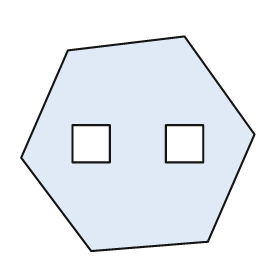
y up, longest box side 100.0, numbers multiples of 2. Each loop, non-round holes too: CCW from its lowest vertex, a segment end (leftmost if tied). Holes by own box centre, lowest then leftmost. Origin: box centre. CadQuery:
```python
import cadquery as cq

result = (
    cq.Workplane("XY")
    .moveTo(-20.0, -46.0)
    .lineTo(30.0, -42.0)
    .lineTo(50.0, 4.0)
    .lineTo(20.0, 46.0)
    .lineTo(-30.0, 40.0)
    .lineTo(-50.0, -6.0)
    .close()
    .moveTo(-28.0, -8.0)
    .lineTo(-12.0, -8.0)
    .lineTo(-12.0, 8.0)
    .lineTo(-28.0, 8.0)
    .close()
    .moveTo(12.0, -8.0)
    .lineTo(28.0, -8.0)
    .lineTo(28.0, 8.0)
    .lineTo(12.0, 8.0)
    .close()
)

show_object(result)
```